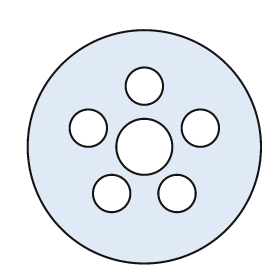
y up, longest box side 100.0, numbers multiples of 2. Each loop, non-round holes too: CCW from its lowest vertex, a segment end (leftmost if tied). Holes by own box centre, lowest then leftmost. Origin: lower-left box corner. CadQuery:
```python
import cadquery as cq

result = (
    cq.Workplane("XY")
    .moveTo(50.0, 50.0)
    .circle(50.0)
    .moveTo(36.0, 30.0)
    .circle(8.0)
    .moveTo(64.0, 30.0)
    .circle(8.0)
    .moveTo(50.0, 50.0)
    .circle(12.0)
    .moveTo(26.0, 58.0)
    .circle(8.0)
    .moveTo(74.0, 58.0)
    .circle(8.0)
    .moveTo(50.0, 76.0)
    .circle(8.0)
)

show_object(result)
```